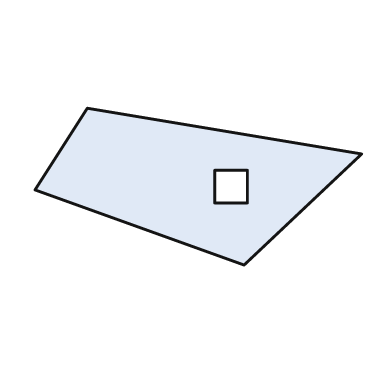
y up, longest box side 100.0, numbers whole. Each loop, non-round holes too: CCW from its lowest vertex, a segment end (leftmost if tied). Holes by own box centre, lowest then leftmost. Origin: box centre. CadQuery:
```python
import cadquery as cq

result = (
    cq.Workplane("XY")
    .moveTo(14.0, -24.0)
    .lineTo(50.0, 10.0)
    .lineTo(-34.0, 24.0)
    .lineTo(-50.0, -1.0)
    .close()
    .moveTo(5.0, -5.0)
    .lineTo(15.0, -5.0)
    .lineTo(15.0, 5.0)
    .lineTo(5.0, 5.0)
    .close()
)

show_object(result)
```